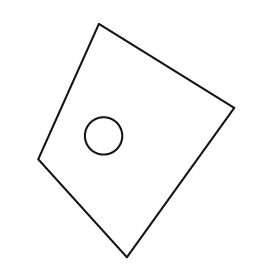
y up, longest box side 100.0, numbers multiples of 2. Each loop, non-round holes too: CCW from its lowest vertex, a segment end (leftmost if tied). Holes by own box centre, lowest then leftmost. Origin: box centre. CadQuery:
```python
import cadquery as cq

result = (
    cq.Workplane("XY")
    .moveTo(-4.0, -50.0)
    .lineTo(42.0, 14.0)
    .lineTo(-16.0, 50.0)
    .lineTo(-42.0, -8.0)
    .close()
    .moveTo(-14.0, 2.0)
    .circle(8.0)
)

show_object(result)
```